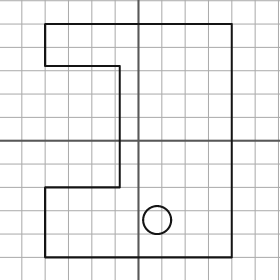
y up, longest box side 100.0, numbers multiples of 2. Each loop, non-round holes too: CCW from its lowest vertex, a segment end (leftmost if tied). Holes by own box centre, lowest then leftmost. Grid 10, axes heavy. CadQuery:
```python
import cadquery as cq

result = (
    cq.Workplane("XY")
    .moveTo(-40.0, -50.0)
    .lineTo(40.0, -50.0)
    .lineTo(40.0, 50.0)
    .lineTo(-40.0, 50.0)
    .lineTo(-40.0, 32.0)
    .lineTo(-8.0, 32.0)
    .lineTo(-8.0, -20.0)
    .lineTo(-40.0, -20.0)
    .close()
    .moveTo(8.0, -34.0)
    .circle(6.0)
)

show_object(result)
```